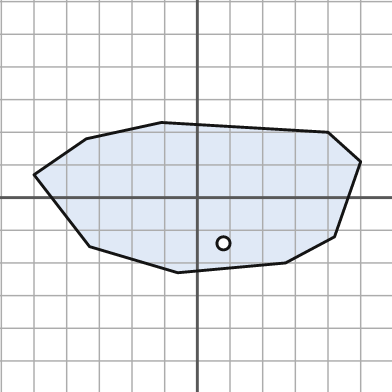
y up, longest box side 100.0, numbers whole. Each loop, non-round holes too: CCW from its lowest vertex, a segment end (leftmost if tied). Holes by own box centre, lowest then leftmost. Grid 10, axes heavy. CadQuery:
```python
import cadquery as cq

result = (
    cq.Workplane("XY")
    .moveTo(-6.0, -23.0)
    .lineTo(27.0, -20.0)
    .lineTo(42.0, -12.0)
    .lineTo(50.0, 11.0)
    .lineTo(40.0, 20.0)
    .lineTo(-11.0, 23.0)
    .lineTo(-34.0, 18.0)
    .lineTo(-50.0, 7.0)
    .lineTo(-33.0, -15.0)
    .close()
    .moveTo(8.0, -14.0)
    .circle(2.0)
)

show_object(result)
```